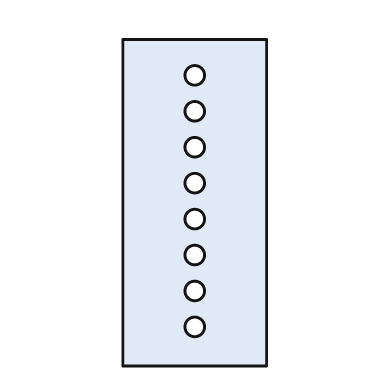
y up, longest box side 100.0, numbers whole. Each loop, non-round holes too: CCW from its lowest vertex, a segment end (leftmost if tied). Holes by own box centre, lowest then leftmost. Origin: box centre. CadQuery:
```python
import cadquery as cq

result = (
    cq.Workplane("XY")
    .moveTo(-22.0, -50.0)
    .lineTo(22.0, -50.0)
    .lineTo(22.0, 50.0)
    .lineTo(-22.0, 50.0)
    .close()
    .moveTo(0.0, -38.0)
    .circle(3.0)
    .moveTo(0.0, -27.0)
    .circle(3.0)
    .moveTo(0.0, -16.0)
    .circle(3.0)
    .moveTo(0.0, -5.0)
    .circle(3.0)
    .moveTo(0.0, 6.0)
    .circle(3.0)
    .moveTo(0.0, 17.0)
    .circle(3.0)
    .moveTo(0.0, 28.0)
    .circle(3.0)
    .moveTo(0.0, 39.0)
    .circle(3.0)
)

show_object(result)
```